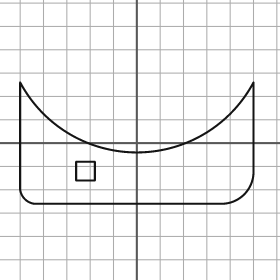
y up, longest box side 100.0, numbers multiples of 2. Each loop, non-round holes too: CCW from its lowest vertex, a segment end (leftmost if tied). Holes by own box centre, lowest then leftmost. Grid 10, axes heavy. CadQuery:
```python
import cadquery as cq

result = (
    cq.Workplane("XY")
    .moveTo(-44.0, -26.0)
    .lineTo(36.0, -26.0)
    .threePointArc((46.0, -22.0), (50.0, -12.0))
    .lineTo(50.0, 26.0)
    .threePointArc((0.0, -4.0), (-50.0, 26.0))
    .lineTo(-50.0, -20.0)
    .threePointArc((-48.0, -24.0), (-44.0, -26.0))
    .close()
    .moveTo(-26.0, -16.0)
    .lineTo(-18.0, -16.0)
    .lineTo(-18.0, -8.0)
    .lineTo(-26.0, -8.0)
    .close()
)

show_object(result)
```